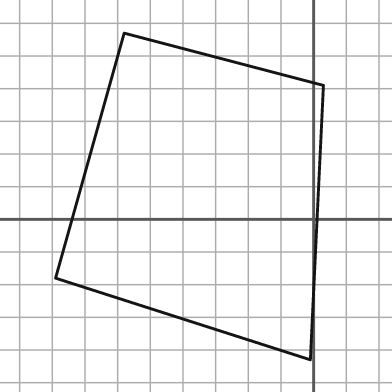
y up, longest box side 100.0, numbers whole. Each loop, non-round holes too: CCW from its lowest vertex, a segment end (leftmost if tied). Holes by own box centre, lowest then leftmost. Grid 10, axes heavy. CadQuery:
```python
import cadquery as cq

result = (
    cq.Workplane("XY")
    .moveTo(-1.0, -43.0)
    .lineTo(3.0, 41.0)
    .lineTo(-58.0, 57.0)
    .lineTo(-79.0, -18.0)
    .close()
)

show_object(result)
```